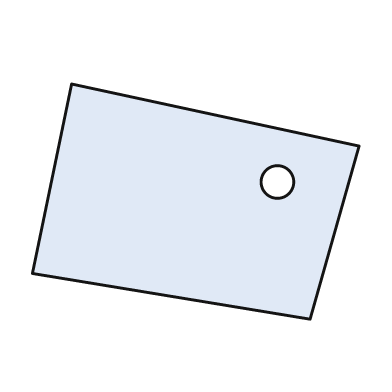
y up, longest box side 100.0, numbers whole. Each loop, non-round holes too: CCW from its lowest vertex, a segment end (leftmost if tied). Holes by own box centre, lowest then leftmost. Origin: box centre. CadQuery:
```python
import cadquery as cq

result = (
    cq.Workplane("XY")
    .moveTo(35.0, -36.0)
    .lineTo(50.0, 17.0)
    .lineTo(-38.0, 36.0)
    .lineTo(-50.0, -22.0)
    .close()
    .moveTo(25.0, 6.0)
    .circle(5.0)
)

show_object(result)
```